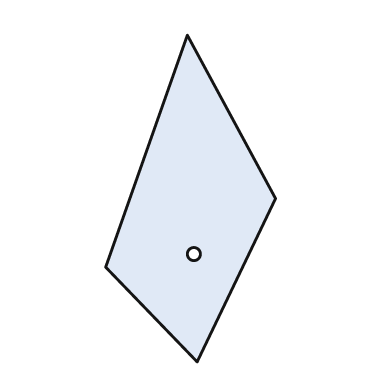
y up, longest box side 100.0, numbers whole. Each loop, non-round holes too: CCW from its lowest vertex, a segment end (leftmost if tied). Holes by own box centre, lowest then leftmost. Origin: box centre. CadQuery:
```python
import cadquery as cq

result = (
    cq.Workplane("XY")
    .moveTo(2.0, -50.0)
    .lineTo(26.0, 0.0)
    .lineTo(-1.0, 50.0)
    .lineTo(-26.0, -21.0)
    .close()
    .moveTo(1.0, -17.0)
    .circle(2.0)
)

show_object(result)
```